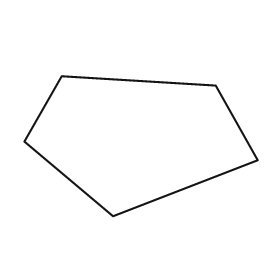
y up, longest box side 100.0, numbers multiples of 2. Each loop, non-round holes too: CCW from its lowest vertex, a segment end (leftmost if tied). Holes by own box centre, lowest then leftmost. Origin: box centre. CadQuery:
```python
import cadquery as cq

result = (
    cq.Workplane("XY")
    .moveTo(-12.0, -30.0)
    .lineTo(50.0, -6.0)
    .lineTo(32.0, 26.0)
    .lineTo(-34.0, 30.0)
    .lineTo(-50.0, 2.0)
    .close()
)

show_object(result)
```